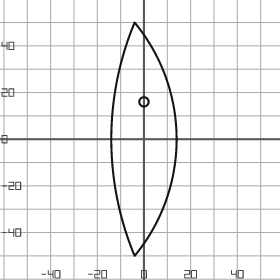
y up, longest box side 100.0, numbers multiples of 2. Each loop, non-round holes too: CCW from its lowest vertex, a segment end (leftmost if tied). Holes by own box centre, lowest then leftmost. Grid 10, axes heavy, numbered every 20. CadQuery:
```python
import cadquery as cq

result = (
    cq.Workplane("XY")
    .moveTo(-4.0, -50.0)
    .threePointArc((14.0, 0.0), (-4.0, 50.0))
    .threePointArc((-14.0, 0.0), (-4.0, -50.0))
    .close()
    .moveTo(0.0, 16.0)
    .circle(2.0)
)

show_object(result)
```